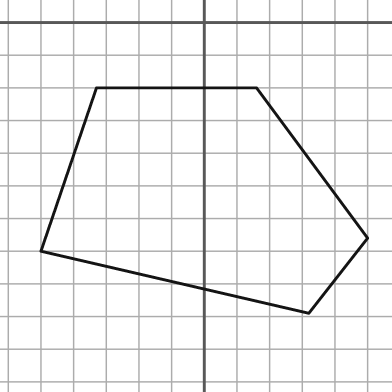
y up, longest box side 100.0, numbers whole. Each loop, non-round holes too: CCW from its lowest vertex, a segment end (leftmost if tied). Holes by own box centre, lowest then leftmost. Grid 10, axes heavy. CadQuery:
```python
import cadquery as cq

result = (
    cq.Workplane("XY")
    .moveTo(32.0, -89.0)
    .lineTo(50.0, -66.0)
    .lineTo(16.0, -20.0)
    .lineTo(-33.0, -20.0)
    .lineTo(-50.0, -70.0)
    .close()
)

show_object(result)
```